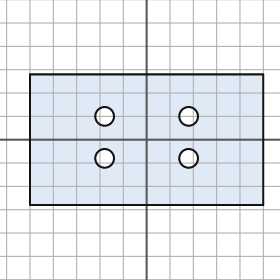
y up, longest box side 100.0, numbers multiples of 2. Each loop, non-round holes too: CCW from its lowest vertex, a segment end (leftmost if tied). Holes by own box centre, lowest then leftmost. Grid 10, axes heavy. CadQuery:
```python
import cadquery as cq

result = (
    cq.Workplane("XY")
    .moveTo(-50.0, -28.0)
    .lineTo(50.0, -28.0)
    .lineTo(50.0, 28.0)
    .lineTo(-50.0, 28.0)
    .close()
    .moveTo(-18.0, -8.0)
    .circle(4.0)
    .moveTo(18.0, -8.0)
    .circle(4.0)
    .moveTo(-18.0, 10.0)
    .circle(4.0)
    .moveTo(18.0, 10.0)
    .circle(4.0)
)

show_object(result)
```